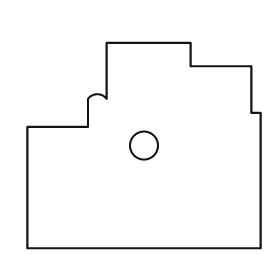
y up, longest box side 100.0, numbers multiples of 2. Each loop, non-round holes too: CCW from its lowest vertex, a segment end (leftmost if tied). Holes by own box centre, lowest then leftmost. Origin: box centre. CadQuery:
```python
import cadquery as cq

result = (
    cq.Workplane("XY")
    .moveTo(-50.0, -44.0)
    .lineTo(50.0, -44.0)
    .lineTo(50.0, 14.0)
    .lineTo(46.0, 14.0)
    .lineTo(46.0, 34.0)
    .lineTo(20.0, 34.0)
    .lineTo(20.0, 44.0)
    .lineTo(-16.0, 44.0)
    .lineTo(-16.0, 20.0)
    .threePointArc((-20.0, 22.0), (-24.0, 20.0))
    .lineTo(-24.0, 8.0)
    .lineTo(-50.0, 8.0)
    .close()
    .moveTo(0.0, 0.0)
    .circle(6.0)
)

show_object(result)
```